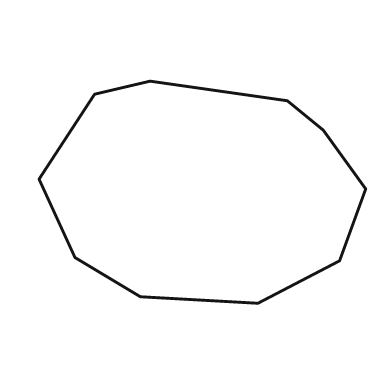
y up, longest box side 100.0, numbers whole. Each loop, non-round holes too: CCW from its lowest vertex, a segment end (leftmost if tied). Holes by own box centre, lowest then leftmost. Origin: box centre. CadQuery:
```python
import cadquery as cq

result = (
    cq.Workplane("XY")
    .moveTo(17.0, -34.0)
    .lineTo(42.0, -21.0)
    .lineTo(50.0, 1.0)
    .lineTo(37.0, 19.0)
    .lineTo(26.0, 28.0)
    .lineTo(-16.0, 34.0)
    .lineTo(-33.0, 30.0)
    .lineTo(-50.0, 4.0)
    .lineTo(-39.0, -20.0)
    .lineTo(-19.0, -32.0)
    .close()
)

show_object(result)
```